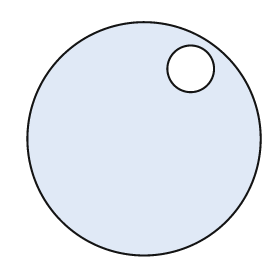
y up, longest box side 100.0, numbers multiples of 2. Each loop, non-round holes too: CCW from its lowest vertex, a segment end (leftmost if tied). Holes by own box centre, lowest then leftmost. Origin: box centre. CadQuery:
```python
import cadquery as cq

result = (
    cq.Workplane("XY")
    .moveTo(0.0, 0.0)
    .circle(50.0)
    .moveTo(20.0, 30.0)
    .circle(10.0)
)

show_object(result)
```